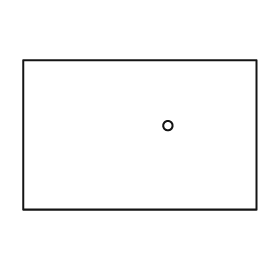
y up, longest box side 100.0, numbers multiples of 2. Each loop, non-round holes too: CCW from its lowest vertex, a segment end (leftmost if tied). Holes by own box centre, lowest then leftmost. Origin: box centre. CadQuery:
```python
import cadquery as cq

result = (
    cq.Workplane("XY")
    .moveTo(-50.0, -32.0)
    .lineTo(50.0, -32.0)
    .lineTo(50.0, 32.0)
    .lineTo(-50.0, 32.0)
    .close()
    .moveTo(12.0, 4.0)
    .circle(2.0)
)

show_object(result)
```